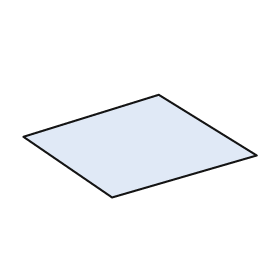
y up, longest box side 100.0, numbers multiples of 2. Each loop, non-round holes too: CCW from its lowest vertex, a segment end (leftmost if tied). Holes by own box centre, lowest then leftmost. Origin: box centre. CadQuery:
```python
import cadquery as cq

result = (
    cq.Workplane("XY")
    .moveTo(-12.0, -22.0)
    .lineTo(50.0, -4.0)
    .lineTo(8.0, 22.0)
    .lineTo(-50.0, 4.0)
    .close()
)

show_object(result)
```